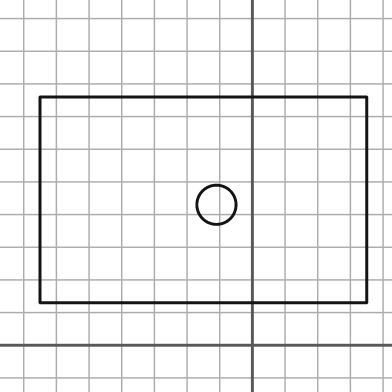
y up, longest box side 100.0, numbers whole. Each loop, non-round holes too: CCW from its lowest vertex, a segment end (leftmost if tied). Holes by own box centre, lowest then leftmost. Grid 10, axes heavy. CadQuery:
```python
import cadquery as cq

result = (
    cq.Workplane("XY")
    .moveTo(-65.0, 13.0)
    .lineTo(35.0, 13.0)
    .lineTo(35.0, 76.0)
    .lineTo(-65.0, 76.0)
    .close()
    .moveTo(-11.0, 43.0)
    .circle(6.0)
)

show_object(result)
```